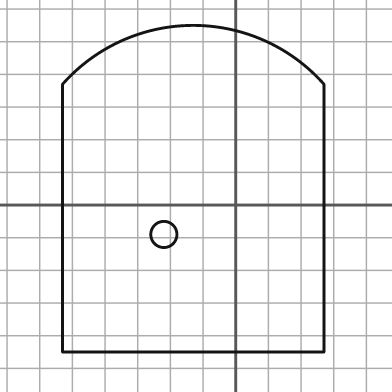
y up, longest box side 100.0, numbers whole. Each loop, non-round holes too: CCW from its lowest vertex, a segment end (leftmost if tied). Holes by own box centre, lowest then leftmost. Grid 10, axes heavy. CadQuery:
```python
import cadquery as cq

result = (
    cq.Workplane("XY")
    .moveTo(-53.0, -45.0)
    .lineTo(27.0, -45.0)
    .lineTo(27.0, 37.0)
    .threePointArc((-13.0, 55.0), (-53.0, 37.0))
    .close()
    .moveTo(-22.0, -9.0)
    .circle(4.0)
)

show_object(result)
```